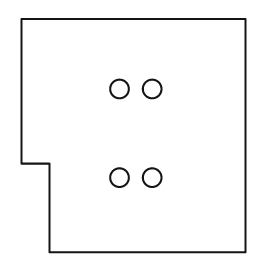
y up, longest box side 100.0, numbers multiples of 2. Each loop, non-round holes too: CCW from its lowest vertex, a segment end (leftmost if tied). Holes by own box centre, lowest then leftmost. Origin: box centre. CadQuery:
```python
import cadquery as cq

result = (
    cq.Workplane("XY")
    .moveTo(-36.0, -50.0)
    .lineTo(48.0, -50.0)
    .lineTo(48.0, 50.0)
    .lineTo(-48.0, 50.0)
    .lineTo(-48.0, -12.0)
    .lineTo(-36.0, -12.0)
    .close()
    .moveTo(-6.0, -18.0)
    .circle(4.0)
    .moveTo(8.0, -18.0)
    .circle(4.0)
    .moveTo(-6.0, 20.0)
    .circle(4.0)
    .moveTo(8.0, 20.0)
    .circle(4.0)
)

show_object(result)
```